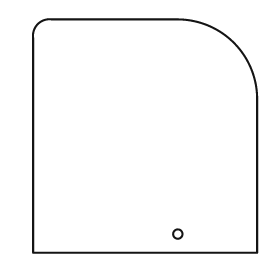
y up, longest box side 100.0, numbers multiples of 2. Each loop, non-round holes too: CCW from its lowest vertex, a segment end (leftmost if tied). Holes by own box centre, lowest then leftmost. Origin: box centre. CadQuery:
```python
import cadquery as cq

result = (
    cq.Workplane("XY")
    .moveTo(-48.0, -50.0)
    .lineTo(48.0, -50.0)
    .lineTo(48.0, 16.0)
    .threePointArc((38.0, 40.0), (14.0, 50.0))
    .lineTo(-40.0, 50.0)
    .threePointArc((-46.0, 48.0), (-48.0, 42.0))
    .close()
    .moveTo(14.0, -42.0)
    .circle(2.0)
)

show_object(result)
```